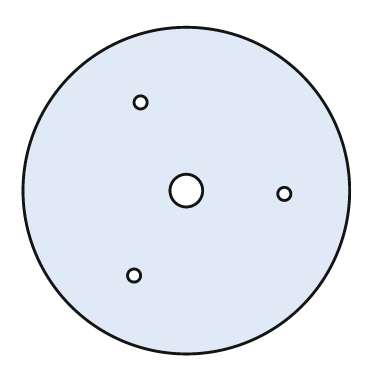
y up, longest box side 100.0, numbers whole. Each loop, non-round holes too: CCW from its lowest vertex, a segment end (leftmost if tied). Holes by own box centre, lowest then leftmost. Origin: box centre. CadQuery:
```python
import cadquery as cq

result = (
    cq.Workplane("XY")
    .moveTo(0.0, 0.0)
    .circle(50.0)
    .moveTo(-16.0, -26.0)
    .circle(2.0)
    .moveTo(30.0, -1.0)
    .circle(2.0)
    .moveTo(0.0, 0.0)
    .circle(5.0)
    .moveTo(-14.0, 27.0)
    .circle(2.0)
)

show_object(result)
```